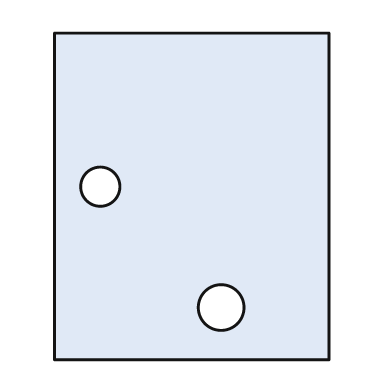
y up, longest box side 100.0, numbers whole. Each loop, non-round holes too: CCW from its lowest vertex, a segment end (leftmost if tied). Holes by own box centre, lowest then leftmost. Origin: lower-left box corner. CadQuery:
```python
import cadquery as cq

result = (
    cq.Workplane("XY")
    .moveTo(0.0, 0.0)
    .lineTo(84.0, 0.0)
    .lineTo(84.0, 100.0)
    .lineTo(0.0, 100.0)
    .close()
    .moveTo(51.0, 16.0)
    .circle(7.0)
    .moveTo(14.0, 53.0)
    .circle(6.0)
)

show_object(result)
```